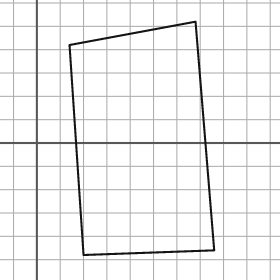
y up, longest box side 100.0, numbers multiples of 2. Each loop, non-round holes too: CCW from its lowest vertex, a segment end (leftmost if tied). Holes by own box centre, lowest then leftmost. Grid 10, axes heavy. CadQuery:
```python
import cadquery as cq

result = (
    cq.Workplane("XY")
    .moveTo(20.0, -48.0)
    .lineTo(76.0, -46.0)
    .lineTo(68.0, 52.0)
    .lineTo(14.0, 42.0)
    .close()
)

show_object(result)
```